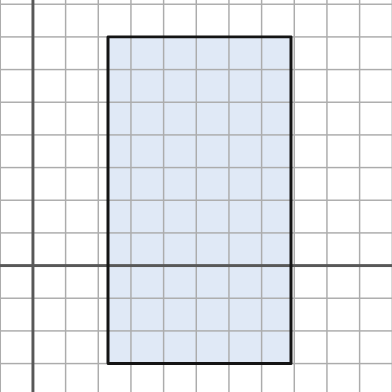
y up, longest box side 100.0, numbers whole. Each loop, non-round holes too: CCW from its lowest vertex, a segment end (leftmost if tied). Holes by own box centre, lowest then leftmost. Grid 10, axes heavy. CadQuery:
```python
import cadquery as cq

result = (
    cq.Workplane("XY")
    .moveTo(23.0, -30.0)
    .lineTo(79.0, -30.0)
    .lineTo(79.0, 70.0)
    .lineTo(23.0, 70.0)
    .close()
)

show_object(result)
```